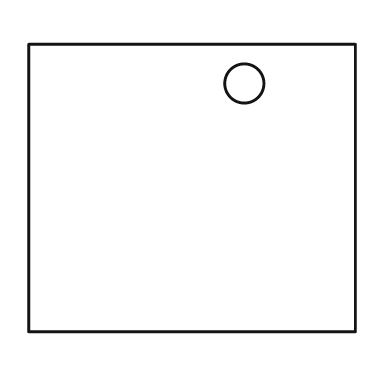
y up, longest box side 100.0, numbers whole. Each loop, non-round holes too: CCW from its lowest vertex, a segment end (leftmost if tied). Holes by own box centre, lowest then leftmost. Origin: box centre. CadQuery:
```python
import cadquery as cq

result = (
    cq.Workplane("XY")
    .moveTo(-50.0, -44.0)
    .lineTo(50.0, -44.0)
    .lineTo(50.0, 44.0)
    .lineTo(-50.0, 44.0)
    .close()
    .moveTo(16.0, 32.0)
    .circle(6.0)
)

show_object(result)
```